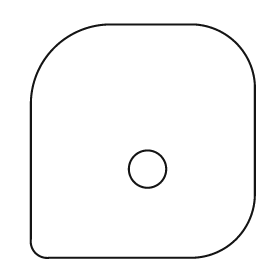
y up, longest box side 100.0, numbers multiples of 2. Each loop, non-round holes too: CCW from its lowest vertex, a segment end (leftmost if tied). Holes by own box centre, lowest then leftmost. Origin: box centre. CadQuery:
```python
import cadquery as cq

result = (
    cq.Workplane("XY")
    .moveTo(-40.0, -50.0)
    .lineTo(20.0, -50.0)
    .threePointArc((40.0, -42.0), (48.0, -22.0))
    .lineTo(48.0, 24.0)
    .threePointArc((40.0, 42.0), (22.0, 50.0))
    .lineTo(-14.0, 50.0)
    .threePointArc((-38.0, 40.0), (-48.0, 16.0))
    .lineTo(-48.0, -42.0)
    .threePointArc((-46.0, -48.0), (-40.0, -50.0))
    .close()
    .moveTo(2.0, -12.0)
    .circle(8.0)
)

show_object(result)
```